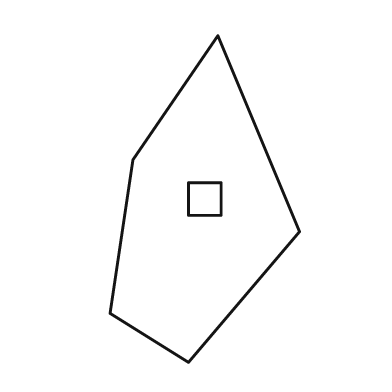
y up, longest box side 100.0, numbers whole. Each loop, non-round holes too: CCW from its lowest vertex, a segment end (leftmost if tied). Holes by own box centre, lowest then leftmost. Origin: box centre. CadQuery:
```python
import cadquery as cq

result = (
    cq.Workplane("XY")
    .moveTo(-5.0, -50.0)
    .lineTo(29.0, -10.0)
    .lineTo(4.0, 50.0)
    .lineTo(-22.0, 12.0)
    .lineTo(-29.0, -35.0)
    .close()
    .moveTo(-5.0, -5.0)
    .lineTo(5.0, -5.0)
    .lineTo(5.0, 5.0)
    .lineTo(-5.0, 5.0)
    .close()
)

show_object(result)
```